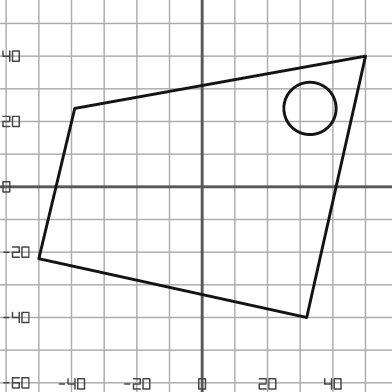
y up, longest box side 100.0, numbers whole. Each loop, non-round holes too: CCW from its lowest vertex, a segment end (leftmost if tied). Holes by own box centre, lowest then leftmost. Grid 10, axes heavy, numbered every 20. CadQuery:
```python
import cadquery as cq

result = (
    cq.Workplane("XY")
    .moveTo(32.0, -40.0)
    .lineTo(50.0, 40.0)
    .lineTo(-39.0, 24.0)
    .lineTo(-50.0, -22.0)
    .close()
    .moveTo(33.0, 24.0)
    .circle(8.0)
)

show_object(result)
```